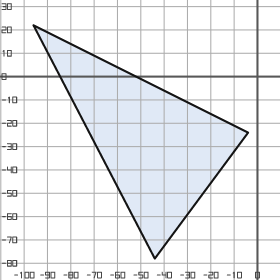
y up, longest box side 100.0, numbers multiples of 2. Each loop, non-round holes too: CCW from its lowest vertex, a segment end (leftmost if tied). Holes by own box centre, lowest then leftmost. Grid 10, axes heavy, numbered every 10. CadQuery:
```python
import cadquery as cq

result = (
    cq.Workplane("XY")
    .moveTo(-44.0, -78.0)
    .lineTo(-4.0, -24.0)
    .lineTo(-96.0, 22.0)
    .close()
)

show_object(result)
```